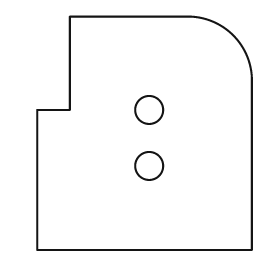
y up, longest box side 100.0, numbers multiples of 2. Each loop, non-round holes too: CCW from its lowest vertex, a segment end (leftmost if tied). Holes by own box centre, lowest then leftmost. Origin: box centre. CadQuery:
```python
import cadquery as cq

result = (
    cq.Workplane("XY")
    .moveTo(-46.0, -50.0)
    .lineTo(46.0, -50.0)
    .lineTo(46.0, 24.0)
    .threePointArc((38.0, 42.0), (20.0, 50.0))
    .lineTo(-32.0, 50.0)
    .lineTo(-32.0, 10.0)
    .lineTo(-46.0, 10.0)
    .close()
    .moveTo(2.0, -14.0)
    .circle(6.0)
    .moveTo(2.0, 10.0)
    .circle(6.0)
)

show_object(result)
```